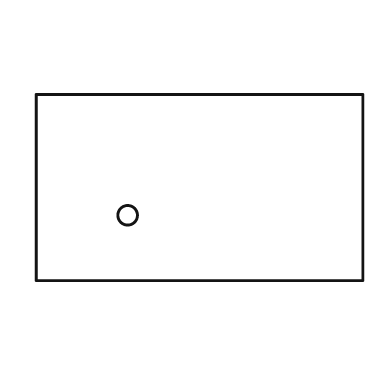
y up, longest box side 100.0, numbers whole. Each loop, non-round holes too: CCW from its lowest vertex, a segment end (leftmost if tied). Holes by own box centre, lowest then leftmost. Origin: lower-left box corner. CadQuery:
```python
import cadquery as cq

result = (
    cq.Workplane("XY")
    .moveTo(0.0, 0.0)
    .lineTo(100.0, 0.0)
    .lineTo(100.0, 57.0)
    .lineTo(0.0, 57.0)
    .close()
    .moveTo(28.0, 20.0)
    .circle(3.0)
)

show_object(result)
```